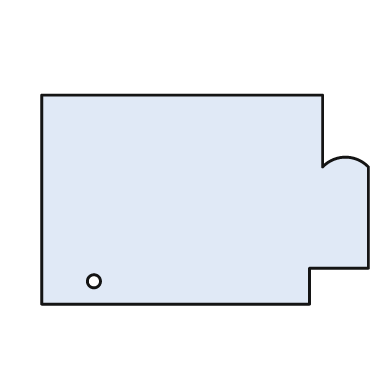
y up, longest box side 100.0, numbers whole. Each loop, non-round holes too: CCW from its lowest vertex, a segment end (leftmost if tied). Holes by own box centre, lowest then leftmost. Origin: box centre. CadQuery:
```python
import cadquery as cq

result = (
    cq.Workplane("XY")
    .moveTo(-50.0, -32.0)
    .lineTo(32.0, -32.0)
    .lineTo(32.0, -21.0)
    .lineTo(50.0, -21.0)
    .lineTo(50.0, 10.0)
    .threePointArc((43.0, 13.0), (36.0, 10.0))
    .lineTo(36.0, 32.0)
    .lineTo(-50.0, 32.0)
    .close()
    .moveTo(-34.0, -25.0)
    .circle(2.0)
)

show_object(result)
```